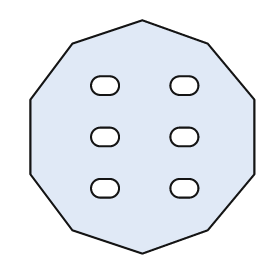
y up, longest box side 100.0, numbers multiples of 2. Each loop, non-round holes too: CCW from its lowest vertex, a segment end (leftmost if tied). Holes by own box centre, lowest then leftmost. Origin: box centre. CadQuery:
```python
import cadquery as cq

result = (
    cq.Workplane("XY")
    .moveTo(0.0, -50.0)
    .lineTo(28.0, -40.0)
    .lineTo(48.0, -16.0)
    .lineTo(48.0, 16.0)
    .lineTo(28.0, 40.0)
    .lineTo(0.0, 50.0)
    .lineTo(-30.0, 40.0)
    .lineTo(-48.0, 16.0)
    .lineTo(-48.0, -16.0)
    .lineTo(-30.0, -40.0)
    .close()
    .moveTo(-18.0, -26.0)
    .lineTo(-14.0, -26.0)
    .threePointArc((-10.0, -22.0), (-14.0, -18.0))
    .lineTo(-18.0, -18.0)
    .threePointArc((-22.0, -22.0), (-18.0, -26.0))
    .close()
    .moveTo(16.0, -26.0)
    .lineTo(20.0, -26.0)
    .threePointArc((24.0, -22.0), (20.0, -18.0))
    .lineTo(16.0, -18.0)
    .threePointArc((12.0, -22.0), (16.0, -26.0))
    .close()
    .moveTo(-18.0, -4.0)
    .lineTo(-14.0, -4.0)
    .threePointArc((-10.0, 0.0), (-14.0, 4.0))
    .lineTo(-18.0, 4.0)
    .threePointArc((-22.0, 0.0), (-18.0, -4.0))
    .close()
    .moveTo(16.0, -4.0)
    .lineTo(20.0, -4.0)
    .threePointArc((24.0, 0.0), (20.0, 4.0))
    .lineTo(16.0, 4.0)
    .threePointArc((12.0, 0.0), (16.0, -4.0))
    .close()
    .moveTo(-18.0, 18.0)
    .lineTo(-14.0, 18.0)
    .threePointArc((-10.0, 22.0), (-14.0, 26.0))
    .lineTo(-18.0, 26.0)
    .threePointArc((-22.0, 22.0), (-18.0, 18.0))
    .close()
    .moveTo(16.0, 18.0)
    .lineTo(20.0, 18.0)
    .threePointArc((24.0, 22.0), (20.0, 26.0))
    .lineTo(16.0, 26.0)
    .threePointArc((12.0, 22.0), (16.0, 18.0))
    .close()
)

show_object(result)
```